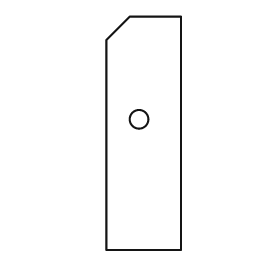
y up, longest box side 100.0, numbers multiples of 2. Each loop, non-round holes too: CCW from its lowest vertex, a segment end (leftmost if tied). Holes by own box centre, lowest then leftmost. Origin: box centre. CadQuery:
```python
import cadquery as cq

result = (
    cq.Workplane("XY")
    .moveTo(-16.0, -50.0)
    .lineTo(16.0, -50.0)
    .lineTo(16.0, 50.0)
    .lineTo(-6.0, 50.0)
    .lineTo(-16.0, 40.0)
    .close()
    .moveTo(-2.0, 6.0)
    .circle(4.0)
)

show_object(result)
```